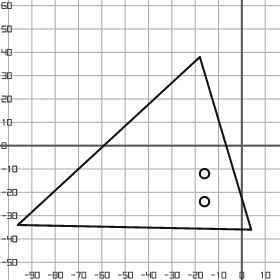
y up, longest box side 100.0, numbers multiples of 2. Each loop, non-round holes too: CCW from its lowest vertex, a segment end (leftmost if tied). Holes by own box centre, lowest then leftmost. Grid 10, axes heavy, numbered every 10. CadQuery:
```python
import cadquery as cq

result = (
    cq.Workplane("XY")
    .moveTo(4.0, -36.0)
    .lineTo(-18.0, 38.0)
    .lineTo(-96.0, -34.0)
    .close()
    .moveTo(-16.0, -24.0)
    .circle(2.0)
    .moveTo(-16.0, -12.0)
    .circle(2.0)
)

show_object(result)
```